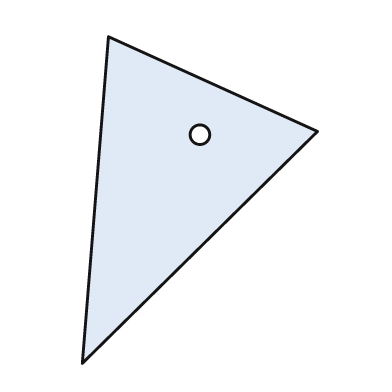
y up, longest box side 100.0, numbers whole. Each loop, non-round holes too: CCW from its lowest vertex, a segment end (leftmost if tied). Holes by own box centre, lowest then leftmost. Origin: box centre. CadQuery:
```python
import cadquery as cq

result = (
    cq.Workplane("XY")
    .moveTo(-36.0, -50.0)
    .lineTo(36.0, 21.0)
    .lineTo(-28.0, 50.0)
    .close()
    .moveTo(0.0, 20.0)
    .circle(3.0)
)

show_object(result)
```